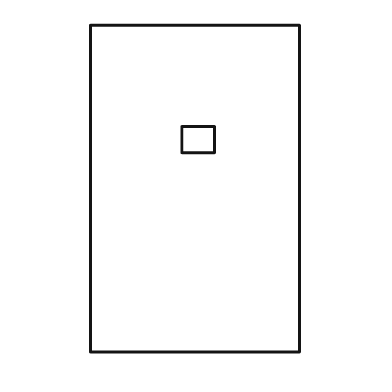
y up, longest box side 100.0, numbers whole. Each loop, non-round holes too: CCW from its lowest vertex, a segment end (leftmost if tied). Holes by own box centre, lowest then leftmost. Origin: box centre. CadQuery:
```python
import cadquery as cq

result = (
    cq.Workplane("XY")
    .moveTo(-32.0, -50.0)
    .lineTo(32.0, -50.0)
    .lineTo(32.0, 50.0)
    .lineTo(-32.0, 50.0)
    .close()
    .moveTo(-4.0, 11.0)
    .lineTo(6.0, 11.0)
    .lineTo(6.0, 19.0)
    .lineTo(-4.0, 19.0)
    .close()
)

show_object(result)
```